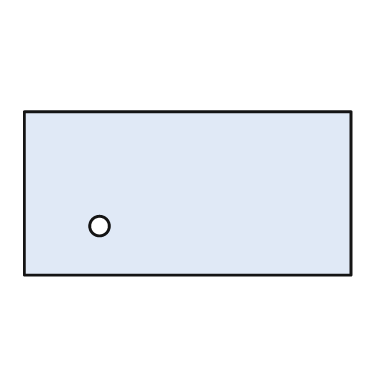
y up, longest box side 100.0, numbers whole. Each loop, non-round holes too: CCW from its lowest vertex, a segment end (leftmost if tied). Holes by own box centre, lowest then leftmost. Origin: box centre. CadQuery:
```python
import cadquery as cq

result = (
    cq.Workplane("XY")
    .moveTo(-50.0, -25.0)
    .lineTo(50.0, -25.0)
    .lineTo(50.0, 25.0)
    .lineTo(-50.0, 25.0)
    .close()
    .moveTo(-27.0, -10.0)
    .circle(3.0)
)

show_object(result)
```